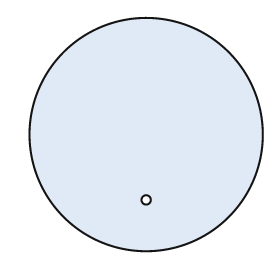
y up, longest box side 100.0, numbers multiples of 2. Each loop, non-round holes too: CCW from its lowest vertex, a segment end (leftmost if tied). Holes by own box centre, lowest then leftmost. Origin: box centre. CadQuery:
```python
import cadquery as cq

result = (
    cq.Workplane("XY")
    .moveTo(0.0, 0.0)
    .circle(50.0)
    .moveTo(0.0, -28.0)
    .circle(2.0)
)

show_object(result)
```